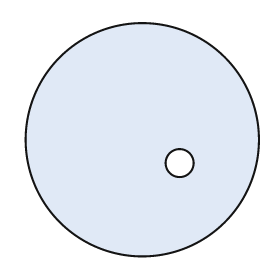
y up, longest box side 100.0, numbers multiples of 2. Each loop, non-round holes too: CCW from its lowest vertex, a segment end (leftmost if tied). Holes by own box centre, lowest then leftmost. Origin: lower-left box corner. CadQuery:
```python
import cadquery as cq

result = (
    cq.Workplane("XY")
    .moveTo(50.0, 50.0)
    .circle(50.0)
    .moveTo(66.0, 40.0)
    .circle(6.0)
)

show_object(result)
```